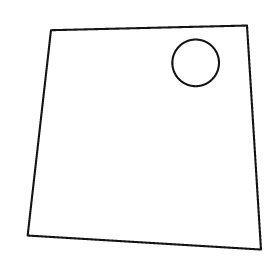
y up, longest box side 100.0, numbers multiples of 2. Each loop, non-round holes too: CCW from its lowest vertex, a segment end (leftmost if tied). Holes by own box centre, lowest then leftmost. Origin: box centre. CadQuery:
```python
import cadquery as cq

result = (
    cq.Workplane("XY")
    .moveTo(50.0, -48.0)
    .lineTo(44.0, 48.0)
    .lineTo(-40.0, 46.0)
    .lineTo(-50.0, -42.0)
    .close()
    .moveTo(22.0, 32.0)
    .circle(10.0)
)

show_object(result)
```